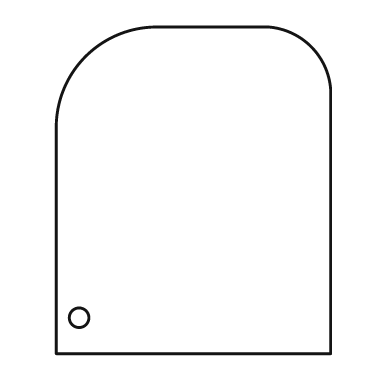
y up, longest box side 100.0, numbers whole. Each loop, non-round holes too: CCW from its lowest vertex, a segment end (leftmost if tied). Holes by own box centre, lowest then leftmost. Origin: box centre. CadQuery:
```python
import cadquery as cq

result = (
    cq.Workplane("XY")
    .moveTo(-42.0, -50.0)
    .lineTo(42.0, -50.0)
    .lineTo(42.0, 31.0)
    .threePointArc((36.0, 44.0), (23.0, 50.0))
    .lineTo(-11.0, 50.0)
    .threePointArc((-33.0, 41.0), (-42.0, 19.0))
    .close()
    .moveTo(-35.0, -39.0)
    .circle(3.0)
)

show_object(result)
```